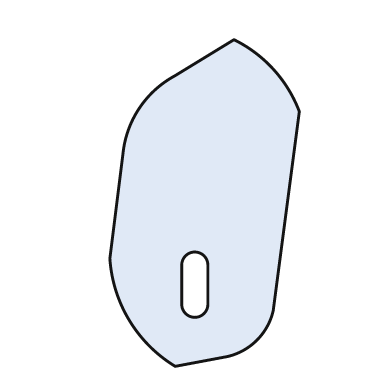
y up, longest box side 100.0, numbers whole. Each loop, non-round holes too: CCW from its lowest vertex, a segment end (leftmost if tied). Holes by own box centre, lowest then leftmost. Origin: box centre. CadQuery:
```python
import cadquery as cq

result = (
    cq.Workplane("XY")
    .moveTo(-9.0, -50.0)
    .lineTo(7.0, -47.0)
    .threePointArc((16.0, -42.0), (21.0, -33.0))
    .lineTo(29.0, 28.0)
    .threePointArc((21.0, 41.0), (9.0, 50.0))
    .lineTo(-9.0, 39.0)
    .threePointArc((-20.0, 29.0), (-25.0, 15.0))
    .lineTo(-29.0, -17.0)
    .threePointArc((-23.0, -36.0), (-9.0, -50.0))
    .close()
    .moveTo(-7.0, -31.0)
    .threePointArc((-3.0, -35.0), (1.0, -31.0))
    .lineTo(1.0, -19.0)
    .threePointArc((-3.0, -15.0), (-7.0, -19.0))
    .close()
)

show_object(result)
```